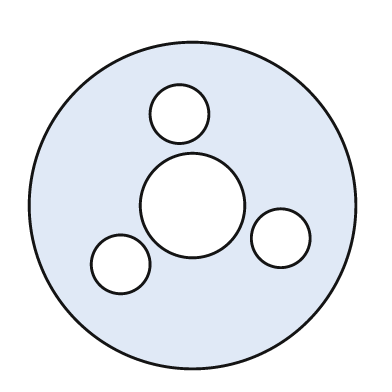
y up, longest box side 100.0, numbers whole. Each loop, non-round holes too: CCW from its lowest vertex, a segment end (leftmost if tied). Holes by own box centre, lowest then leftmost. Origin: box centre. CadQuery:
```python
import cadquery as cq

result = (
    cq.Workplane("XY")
    .moveTo(0.0, 0.0)
    .circle(50.0)
    .moveTo(-22.0, -18.0)
    .circle(9.0)
    .moveTo(27.0, -10.0)
    .circle(9.0)
    .moveTo(0.0, 0.0)
    .circle(16.0)
    .moveTo(-4.0, 28.0)
    .circle(9.0)
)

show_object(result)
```